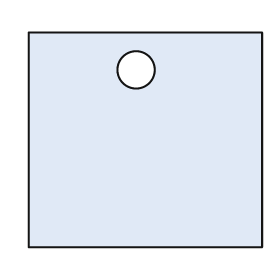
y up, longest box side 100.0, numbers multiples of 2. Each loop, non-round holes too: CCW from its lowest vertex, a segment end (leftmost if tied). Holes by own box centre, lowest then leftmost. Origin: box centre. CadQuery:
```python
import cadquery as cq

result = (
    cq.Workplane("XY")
    .moveTo(-50.0, -46.0)
    .lineTo(50.0, -46.0)
    .lineTo(50.0, 46.0)
    .lineTo(-50.0, 46.0)
    .close()
    .moveTo(-4.0, 30.0)
    .circle(8.0)
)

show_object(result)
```